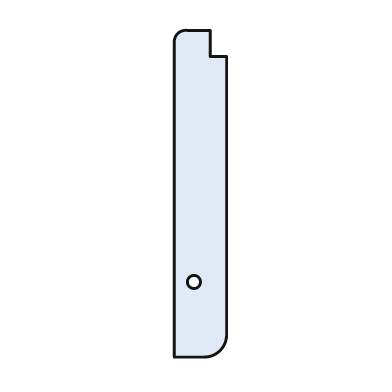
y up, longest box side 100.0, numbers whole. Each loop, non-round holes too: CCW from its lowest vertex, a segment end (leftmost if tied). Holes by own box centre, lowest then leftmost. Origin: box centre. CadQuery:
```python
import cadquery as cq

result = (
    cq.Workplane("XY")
    .moveTo(-8.0, -50.0)
    .lineTo(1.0, -50.0)
    .threePointArc((6.0, -48.0), (8.0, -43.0))
    .lineTo(8.0, 42.0)
    .lineTo(3.0, 42.0)
    .lineTo(3.0, 50.0)
    .lineTo(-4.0, 50.0)
    .threePointArc((-7.0, 49.0), (-8.0, 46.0))
    .close()
    .moveTo(-2.0, -27.0)
    .circle(2.0)
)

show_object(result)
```